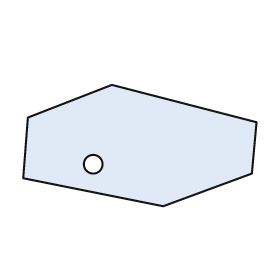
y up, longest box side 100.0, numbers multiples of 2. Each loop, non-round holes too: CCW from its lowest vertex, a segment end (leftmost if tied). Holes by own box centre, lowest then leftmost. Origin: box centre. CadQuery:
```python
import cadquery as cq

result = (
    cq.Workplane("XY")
    .moveTo(10.0, -26.0)
    .lineTo(48.0, -12.0)
    .lineTo(50.0, 10.0)
    .lineTo(-12.0, 26.0)
    .lineTo(-48.0, 12.0)
    .lineTo(-50.0, -14.0)
    .close()
    .moveTo(-20.0, -8.0)
    .circle(4.0)
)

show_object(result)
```